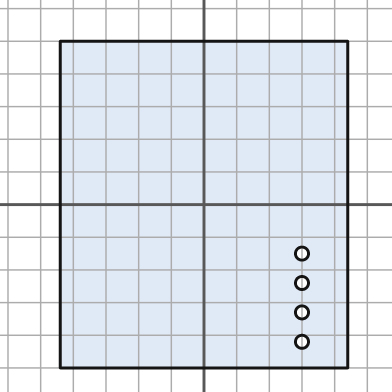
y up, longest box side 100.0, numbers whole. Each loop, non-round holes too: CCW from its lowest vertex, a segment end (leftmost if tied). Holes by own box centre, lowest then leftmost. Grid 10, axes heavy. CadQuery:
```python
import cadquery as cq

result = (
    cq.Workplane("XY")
    .moveTo(-44.0, -50.0)
    .lineTo(44.0, -50.0)
    .lineTo(44.0, 50.0)
    .lineTo(-44.0, 50.0)
    .close()
    .moveTo(30.0, -42.0)
    .circle(2.0)
    .moveTo(30.0, -33.0)
    .circle(2.0)
    .moveTo(30.0, -24.0)
    .circle(2.0)
    .moveTo(30.0, -15.0)
    .circle(2.0)
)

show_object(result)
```